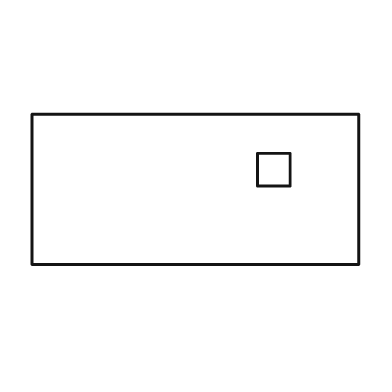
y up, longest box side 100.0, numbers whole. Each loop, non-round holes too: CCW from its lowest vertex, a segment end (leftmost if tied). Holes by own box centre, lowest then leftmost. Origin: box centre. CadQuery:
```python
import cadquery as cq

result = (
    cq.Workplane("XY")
    .moveTo(-50.0, -23.0)
    .lineTo(50.0, -23.0)
    .lineTo(50.0, 23.0)
    .lineTo(-50.0, 23.0)
    .close()
    .moveTo(19.0, 1.0)
    .lineTo(29.0, 1.0)
    .lineTo(29.0, 11.0)
    .lineTo(19.0, 11.0)
    .close()
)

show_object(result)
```